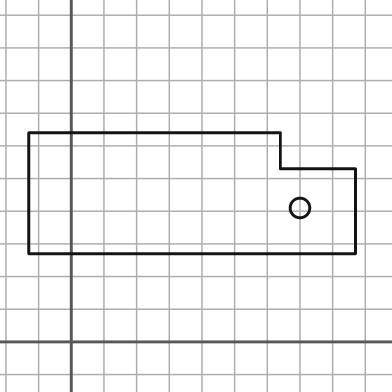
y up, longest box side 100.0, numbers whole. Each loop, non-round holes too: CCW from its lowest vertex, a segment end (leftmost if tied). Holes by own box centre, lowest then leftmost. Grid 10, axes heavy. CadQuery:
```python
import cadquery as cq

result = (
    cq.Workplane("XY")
    .moveTo(-13.0, 27.0)
    .lineTo(87.0, 27.0)
    .lineTo(87.0, 53.0)
    .lineTo(64.0, 53.0)
    .lineTo(64.0, 64.0)
    .lineTo(-13.0, 64.0)
    .close()
    .moveTo(70.0, 41.0)
    .circle(3.0)
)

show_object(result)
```